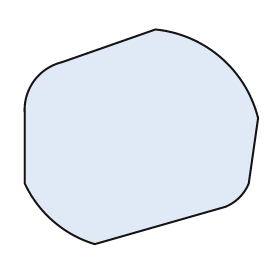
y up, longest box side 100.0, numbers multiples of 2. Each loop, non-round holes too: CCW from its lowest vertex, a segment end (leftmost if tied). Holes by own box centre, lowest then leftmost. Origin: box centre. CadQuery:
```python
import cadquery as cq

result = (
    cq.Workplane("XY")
    .moveTo(-20.0, -46.0)
    .lineTo(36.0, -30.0)
    .threePointArc((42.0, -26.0), (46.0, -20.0))
    .lineTo(50.0, 8.0)
    .threePointArc((34.0, 34.0), (6.0, 46.0))
    .lineTo(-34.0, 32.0)
    .threePointArc((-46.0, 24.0), (-50.0, 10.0))
    .lineTo(-50.0, -20.0)
    .threePointArc((-38.0, -36.0), (-20.0, -46.0))
    .close()
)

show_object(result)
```